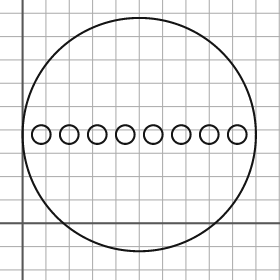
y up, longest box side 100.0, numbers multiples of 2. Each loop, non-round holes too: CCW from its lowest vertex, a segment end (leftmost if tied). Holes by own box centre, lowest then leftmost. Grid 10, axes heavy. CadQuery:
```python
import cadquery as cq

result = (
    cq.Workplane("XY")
    .moveTo(50.0, 38.0)
    .circle(50.0)
    .moveTo(8.0, 38.0)
    .circle(4.0)
    .moveTo(20.0, 38.0)
    .circle(4.0)
    .moveTo(32.0, 38.0)
    .circle(4.0)
    .moveTo(44.0, 38.0)
    .circle(4.0)
    .moveTo(56.0, 38.0)
    .circle(4.0)
    .moveTo(68.0, 38.0)
    .circle(4.0)
    .moveTo(80.0, 38.0)
    .circle(4.0)
    .moveTo(92.0, 38.0)
    .circle(4.0)
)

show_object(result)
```